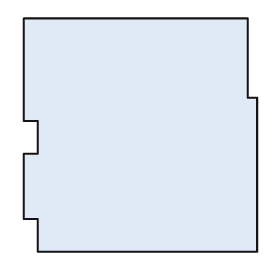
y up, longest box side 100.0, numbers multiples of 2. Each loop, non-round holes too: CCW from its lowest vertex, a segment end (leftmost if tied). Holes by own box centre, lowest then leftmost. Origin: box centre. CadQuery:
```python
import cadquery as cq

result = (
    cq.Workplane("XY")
    .moveTo(-44.0, -50.0)
    .lineTo(50.0, -50.0)
    .lineTo(50.0, 16.0)
    .lineTo(46.0, 16.0)
    .lineTo(46.0, 50.0)
    .lineTo(-50.0, 50.0)
    .lineTo(-50.0, 6.0)
    .lineTo(-44.0, 6.0)
    .lineTo(-44.0, -8.0)
    .lineTo(-50.0, -8.0)
    .lineTo(-50.0, -36.0)
    .lineTo(-44.0, -36.0)
    .close()
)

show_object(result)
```